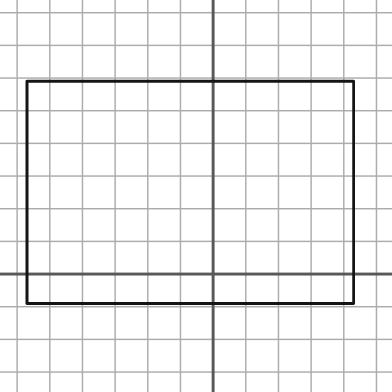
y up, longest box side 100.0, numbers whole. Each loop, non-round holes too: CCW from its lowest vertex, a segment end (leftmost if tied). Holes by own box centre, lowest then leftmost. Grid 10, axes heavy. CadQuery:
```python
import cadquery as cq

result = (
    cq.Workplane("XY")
    .moveTo(-57.0, -9.0)
    .lineTo(43.0, -9.0)
    .lineTo(43.0, 59.0)
    .lineTo(-57.0, 59.0)
    .close()
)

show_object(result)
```